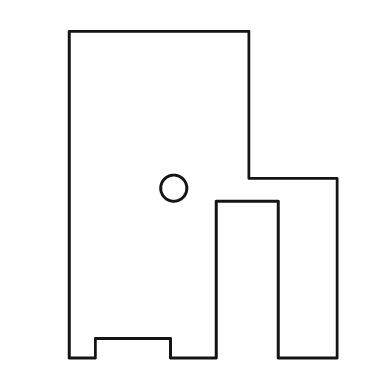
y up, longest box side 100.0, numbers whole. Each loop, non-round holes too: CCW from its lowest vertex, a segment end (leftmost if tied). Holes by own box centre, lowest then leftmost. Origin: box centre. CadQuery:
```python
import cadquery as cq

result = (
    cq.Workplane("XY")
    .moveTo(-41.0, -50.0)
    .lineTo(-33.0, -50.0)
    .lineTo(-33.0, -44.0)
    .lineTo(-10.0, -44.0)
    .lineTo(-10.0, -50.0)
    .lineTo(4.0, -50.0)
    .lineTo(4.0, -2.0)
    .lineTo(23.0, -2.0)
    .lineTo(23.0, -50.0)
    .lineTo(41.0, -50.0)
    .lineTo(41.0, 5.0)
    .lineTo(14.0, 5.0)
    .lineTo(14.0, 50.0)
    .lineTo(-41.0, 50.0)
    .close()
    .moveTo(-9.0, 2.0)
    .circle(4.0)
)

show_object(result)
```